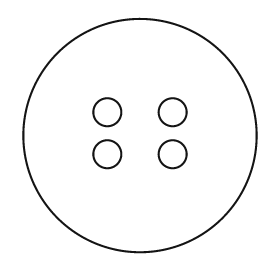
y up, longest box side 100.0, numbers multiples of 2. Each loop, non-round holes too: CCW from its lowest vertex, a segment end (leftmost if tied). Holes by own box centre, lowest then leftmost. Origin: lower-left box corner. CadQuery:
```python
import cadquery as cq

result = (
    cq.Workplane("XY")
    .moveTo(50.0, 50.0)
    .circle(50.0)
    .moveTo(36.0, 42.0)
    .circle(6.0)
    .moveTo(64.0, 42.0)
    .circle(6.0)
    .moveTo(36.0, 60.0)
    .circle(6.0)
    .moveTo(64.0, 60.0)
    .circle(6.0)
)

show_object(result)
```